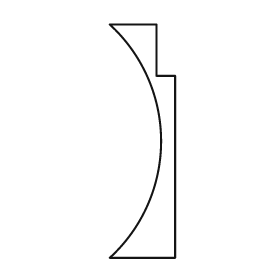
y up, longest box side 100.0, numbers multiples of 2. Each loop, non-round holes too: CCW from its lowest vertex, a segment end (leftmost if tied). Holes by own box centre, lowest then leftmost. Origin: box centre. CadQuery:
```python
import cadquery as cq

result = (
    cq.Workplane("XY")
    .moveTo(-14.0, -50.0)
    .lineTo(14.0, -50.0)
    .lineTo(14.0, 28.0)
    .lineTo(6.0, 28.0)
    .lineTo(6.0, 50.0)
    .lineTo(-14.0, 50.0)
    .threePointArc((8.0, 0.0), (-14.0, -50.0))
    .close()
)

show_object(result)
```